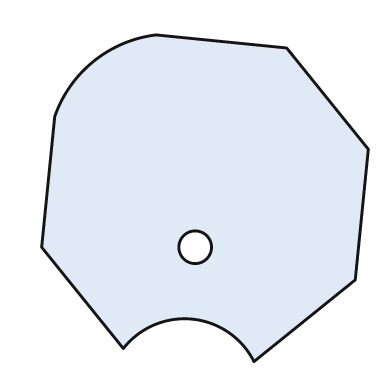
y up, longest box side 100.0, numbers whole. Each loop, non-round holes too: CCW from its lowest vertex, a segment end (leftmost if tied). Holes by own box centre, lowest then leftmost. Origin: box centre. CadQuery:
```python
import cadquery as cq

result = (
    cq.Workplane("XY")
    .moveTo(15.0, -50.0)
    .lineTo(46.0, -25.0)
    .lineTo(50.0, 15.0)
    .lineTo(25.0, 46.0)
    .lineTo(-15.0, 50.0)
    .threePointArc((-34.0, 42.0), (-46.0, 25.0))
    .lineTo(-50.0, -15.0)
    .lineTo(-25.0, -46.0)
    .threePointArc((-4.0, -37.0), (15.0, -50.0))
    .close()
    .moveTo(-3.0, -15.0)
    .circle(5.0)
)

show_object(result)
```